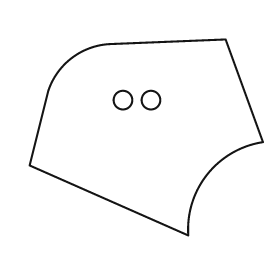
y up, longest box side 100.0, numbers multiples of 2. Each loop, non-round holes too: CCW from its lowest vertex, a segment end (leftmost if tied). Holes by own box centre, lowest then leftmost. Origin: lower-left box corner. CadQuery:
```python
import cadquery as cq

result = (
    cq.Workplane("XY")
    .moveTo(68.0, 0.0)
    .threePointArc((76.0, 26.0), (100.0, 40.0))
    .lineTo(84.0, 84.0)
    .lineTo(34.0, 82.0)
    .threePointArc((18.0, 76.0), (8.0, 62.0))
    .lineTo(0.0, 30.0)
    .close()
    .moveTo(40.0, 58.0)
    .circle(4.0)
    .moveTo(52.0, 58.0)
    .circle(4.0)
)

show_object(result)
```